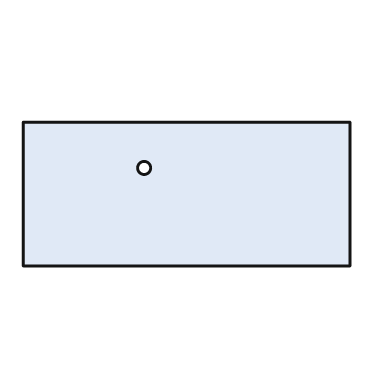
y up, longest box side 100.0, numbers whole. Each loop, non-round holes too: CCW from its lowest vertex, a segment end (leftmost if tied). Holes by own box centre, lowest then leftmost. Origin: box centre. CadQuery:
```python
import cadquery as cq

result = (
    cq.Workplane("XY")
    .moveTo(-50.0, -22.0)
    .lineTo(50.0, -22.0)
    .lineTo(50.0, 22.0)
    .lineTo(-50.0, 22.0)
    .close()
    .moveTo(-13.0, 8.0)
    .circle(2.0)
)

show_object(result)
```